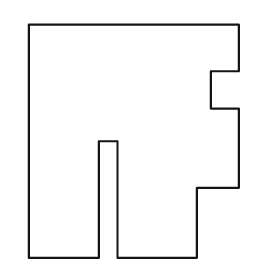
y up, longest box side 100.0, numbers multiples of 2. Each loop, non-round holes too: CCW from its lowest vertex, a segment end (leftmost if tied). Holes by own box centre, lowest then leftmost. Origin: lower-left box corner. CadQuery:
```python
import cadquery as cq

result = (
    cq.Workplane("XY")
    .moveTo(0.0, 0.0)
    .lineTo(30.0, 0.0)
    .lineTo(30.0, 50.0)
    .lineTo(38.0, 50.0)
    .lineTo(38.0, 0.0)
    .lineTo(72.0, 0.0)
    .lineTo(72.0, 30.0)
    .lineTo(90.0, 30.0)
    .lineTo(90.0, 64.0)
    .lineTo(78.0, 64.0)
    .lineTo(78.0, 80.0)
    .lineTo(90.0, 80.0)
    .lineTo(90.0, 100.0)
    .lineTo(0.0, 100.0)
    .close()
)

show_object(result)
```